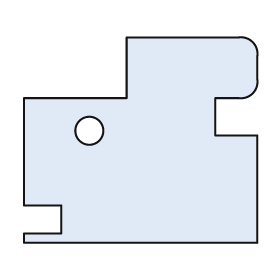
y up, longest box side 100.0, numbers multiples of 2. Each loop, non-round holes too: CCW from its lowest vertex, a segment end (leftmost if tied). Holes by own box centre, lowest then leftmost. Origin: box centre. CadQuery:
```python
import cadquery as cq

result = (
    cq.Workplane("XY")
    .moveTo(-50.0, -44.0)
    .lineTo(50.0, -44.0)
    .lineTo(50.0, 2.0)
    .lineTo(32.0, 2.0)
    .lineTo(32.0, 18.0)
    .lineTo(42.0, 18.0)
    .threePointArc((48.0, 20.0), (50.0, 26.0))
    .lineTo(50.0, 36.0)
    .threePointArc((48.0, 42.0), (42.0, 44.0))
    .lineTo(-6.0, 44.0)
    .lineTo(-6.0, 18.0)
    .lineTo(-50.0, 18.0)
    .lineTo(-50.0, -28.0)
    .lineTo(-34.0, -28.0)
    .lineTo(-34.0, -40.0)
    .lineTo(-50.0, -40.0)
    .close()
    .moveTo(-22.0, 4.0)
    .circle(6.0)
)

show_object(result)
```